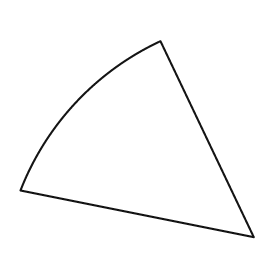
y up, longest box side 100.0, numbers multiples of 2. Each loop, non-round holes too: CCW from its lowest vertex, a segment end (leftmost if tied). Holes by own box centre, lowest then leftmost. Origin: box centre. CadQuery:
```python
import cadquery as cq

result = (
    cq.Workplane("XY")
    .moveTo(50.0, -42.0)
    .lineTo(10.0, 42.0)
    .threePointArc((-26.0, 16.0), (-50.0, -22.0))
    .close()
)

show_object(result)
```